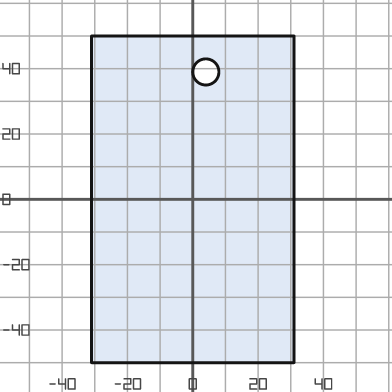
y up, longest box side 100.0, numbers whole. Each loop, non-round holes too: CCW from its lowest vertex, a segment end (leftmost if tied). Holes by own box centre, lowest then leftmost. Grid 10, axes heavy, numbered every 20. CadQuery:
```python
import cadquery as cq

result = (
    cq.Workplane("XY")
    .moveTo(-31.0, -50.0)
    .lineTo(31.0, -50.0)
    .lineTo(31.0, 50.0)
    .lineTo(-31.0, 50.0)
    .close()
    .moveTo(4.0, 39.0)
    .circle(4.0)
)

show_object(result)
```